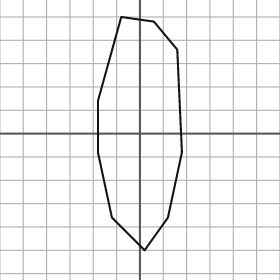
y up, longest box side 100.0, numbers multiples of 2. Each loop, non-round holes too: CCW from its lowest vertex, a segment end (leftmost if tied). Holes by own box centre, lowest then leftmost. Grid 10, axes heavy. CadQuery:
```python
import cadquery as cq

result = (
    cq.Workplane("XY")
    .moveTo(2.0, -50.0)
    .lineTo(12.0, -36.0)
    .lineTo(18.0, -8.0)
    .lineTo(16.0, 36.0)
    .lineTo(6.0, 48.0)
    .lineTo(-8.0, 50.0)
    .lineTo(-18.0, 14.0)
    .lineTo(-18.0, -8.0)
    .lineTo(-12.0, -36.0)
    .close()
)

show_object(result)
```